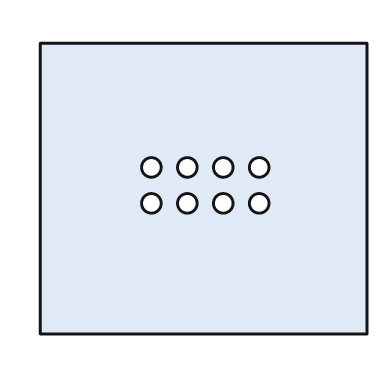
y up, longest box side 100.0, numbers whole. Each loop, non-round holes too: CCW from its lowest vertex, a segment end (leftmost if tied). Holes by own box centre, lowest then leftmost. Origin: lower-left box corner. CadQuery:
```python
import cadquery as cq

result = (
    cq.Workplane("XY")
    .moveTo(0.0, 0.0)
    .lineTo(100.0, 0.0)
    .lineTo(100.0, 89.0)
    .lineTo(0.0, 89.0)
    .close()
    .moveTo(34.0, 40.0)
    .circle(3.0)
    .moveTo(45.0, 40.0)
    .circle(3.0)
    .moveTo(56.0, 40.0)
    .circle(3.0)
    .moveTo(67.0, 40.0)
    .circle(3.0)
    .moveTo(34.0, 51.0)
    .circle(3.0)
    .moveTo(45.0, 51.0)
    .circle(3.0)
    .moveTo(56.0, 51.0)
    .circle(3.0)
    .moveTo(67.0, 51.0)
    .circle(3.0)
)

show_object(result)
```